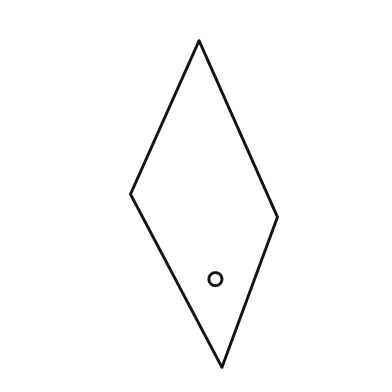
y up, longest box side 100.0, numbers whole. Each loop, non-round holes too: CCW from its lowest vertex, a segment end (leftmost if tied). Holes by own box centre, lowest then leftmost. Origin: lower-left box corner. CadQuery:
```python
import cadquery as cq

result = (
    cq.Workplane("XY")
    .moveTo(28.0, 0.0)
    .lineTo(45.0, 46.0)
    .lineTo(21.0, 100.0)
    .lineTo(0.0, 53.0)
    .close()
    .moveTo(26.0, 27.0)
    .circle(2.0)
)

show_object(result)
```